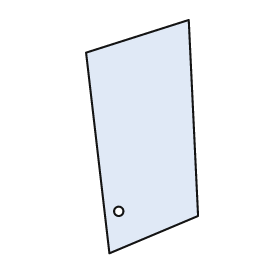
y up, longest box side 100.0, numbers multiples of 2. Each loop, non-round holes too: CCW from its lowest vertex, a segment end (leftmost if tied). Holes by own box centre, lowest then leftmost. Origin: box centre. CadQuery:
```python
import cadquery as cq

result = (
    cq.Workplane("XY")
    .moveTo(-14.0, -50.0)
    .lineTo(24.0, -34.0)
    .lineTo(20.0, 50.0)
    .lineTo(-24.0, 36.0)
    .close()
    .moveTo(-10.0, -32.0)
    .circle(2.0)
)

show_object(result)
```